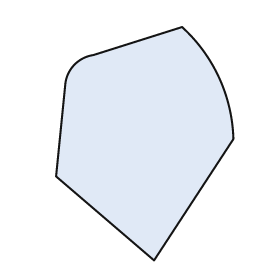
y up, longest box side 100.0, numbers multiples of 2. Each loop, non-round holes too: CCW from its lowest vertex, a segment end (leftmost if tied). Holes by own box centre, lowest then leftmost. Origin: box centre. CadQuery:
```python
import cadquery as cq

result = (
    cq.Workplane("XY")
    .moveTo(4.0, -50.0)
    .lineTo(38.0, 2.0)
    .threePointArc((32.0, 28.0), (16.0, 50.0))
    .lineTo(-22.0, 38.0)
    .threePointArc((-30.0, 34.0), (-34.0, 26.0))
    .lineTo(-38.0, -14.0)
    .close()
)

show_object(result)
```